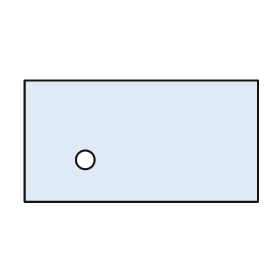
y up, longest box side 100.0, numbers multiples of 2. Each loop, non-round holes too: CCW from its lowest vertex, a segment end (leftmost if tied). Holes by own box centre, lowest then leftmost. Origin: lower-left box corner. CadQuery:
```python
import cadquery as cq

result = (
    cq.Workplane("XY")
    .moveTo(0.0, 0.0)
    .lineTo(100.0, 0.0)
    .lineTo(100.0, 52.0)
    .lineTo(0.0, 52.0)
    .close()
    .moveTo(26.0, 18.0)
    .circle(4.0)
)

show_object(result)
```